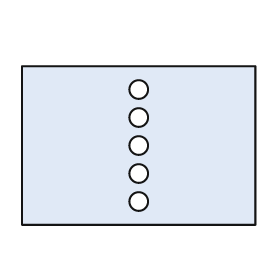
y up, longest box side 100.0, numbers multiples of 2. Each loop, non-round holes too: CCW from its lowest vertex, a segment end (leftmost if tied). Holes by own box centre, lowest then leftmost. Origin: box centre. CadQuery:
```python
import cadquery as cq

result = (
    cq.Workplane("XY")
    .moveTo(-50.0, -34.0)
    .lineTo(50.0, -34.0)
    .lineTo(50.0, 34.0)
    .lineTo(-50.0, 34.0)
    .close()
    .moveTo(0.0, -24.0)
    .circle(4.0)
    .moveTo(0.0, -12.0)
    .circle(4.0)
    .moveTo(0.0, 0.0)
    .circle(4.0)
    .moveTo(0.0, 12.0)
    .circle(4.0)
    .moveTo(0.0, 24.0)
    .circle(4.0)
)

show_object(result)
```